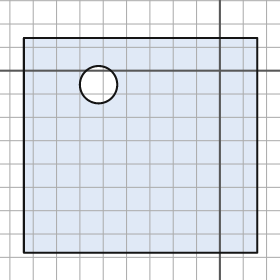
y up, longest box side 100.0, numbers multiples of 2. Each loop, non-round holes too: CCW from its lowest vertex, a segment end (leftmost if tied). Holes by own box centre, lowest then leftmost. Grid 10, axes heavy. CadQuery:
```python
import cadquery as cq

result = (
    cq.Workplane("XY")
    .moveTo(-84.0, -78.0)
    .lineTo(16.0, -78.0)
    .lineTo(16.0, 14.0)
    .lineTo(-84.0, 14.0)
    .close()
    .moveTo(-52.0, -6.0)
    .circle(8.0)
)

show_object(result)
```